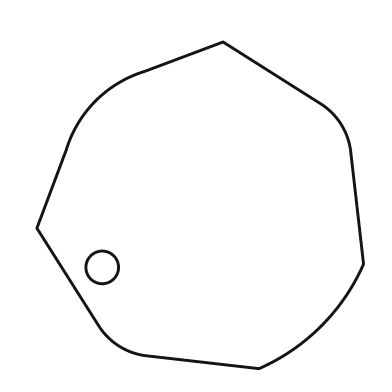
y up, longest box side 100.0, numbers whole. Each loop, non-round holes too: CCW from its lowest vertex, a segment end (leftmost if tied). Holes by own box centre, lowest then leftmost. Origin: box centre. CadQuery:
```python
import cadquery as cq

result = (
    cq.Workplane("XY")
    .moveTo(18.0, -50.0)
    .threePointArc((37.0, -37.0), (50.0, -18.0))
    .lineTo(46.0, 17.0)
    .threePointArc((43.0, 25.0), (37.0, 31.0))
    .lineTo(7.0, 50.0)
    .lineTo(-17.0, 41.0)
    .threePointArc((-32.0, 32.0), (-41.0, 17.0))
    .lineTo(-50.0, -7.0)
    .lineTo(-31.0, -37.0)
    .threePointArc((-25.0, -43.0), (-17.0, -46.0))
    .close()
    .moveTo(-30.0, -19.0)
    .circle(5.0)
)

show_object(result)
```